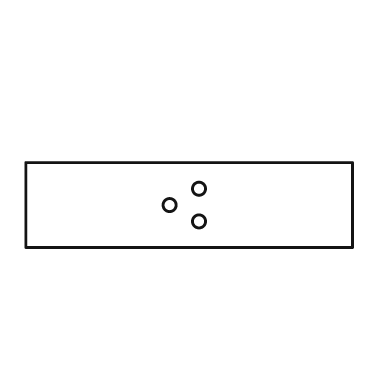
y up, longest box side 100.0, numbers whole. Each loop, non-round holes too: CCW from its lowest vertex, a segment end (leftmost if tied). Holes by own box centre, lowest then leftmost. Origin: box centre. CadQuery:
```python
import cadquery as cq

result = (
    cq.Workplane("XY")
    .moveTo(-50.0, -13.0)
    .lineTo(50.0, -13.0)
    .lineTo(50.0, 13.0)
    .lineTo(-50.0, 13.0)
    .close()
    .moveTo(3.0, -5.0)
    .circle(2.0)
    .moveTo(-6.0, 0.0)
    .circle(2.0)
    .moveTo(3.0, 5.0)
    .circle(2.0)
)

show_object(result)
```